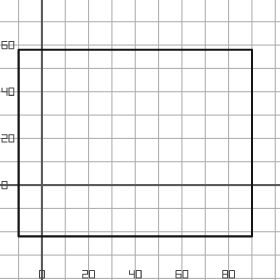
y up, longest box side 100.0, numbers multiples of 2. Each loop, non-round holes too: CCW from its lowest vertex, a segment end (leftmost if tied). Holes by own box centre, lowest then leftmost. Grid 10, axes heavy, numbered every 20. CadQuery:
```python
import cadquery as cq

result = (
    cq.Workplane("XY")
    .moveTo(-10.0, -22.0)
    .lineTo(90.0, -22.0)
    .lineTo(90.0, 58.0)
    .lineTo(-10.0, 58.0)
    .close()
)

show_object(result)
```